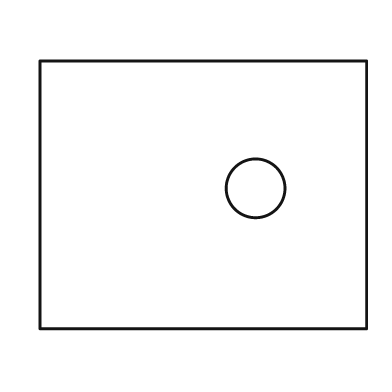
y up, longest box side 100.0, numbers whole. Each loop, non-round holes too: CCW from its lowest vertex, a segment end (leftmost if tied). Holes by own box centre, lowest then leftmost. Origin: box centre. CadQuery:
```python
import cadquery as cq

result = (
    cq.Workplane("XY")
    .moveTo(-50.0, -41.0)
    .lineTo(50.0, -41.0)
    .lineTo(50.0, 41.0)
    .lineTo(-50.0, 41.0)
    .close()
    .moveTo(16.0, 2.0)
    .circle(9.0)
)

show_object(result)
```